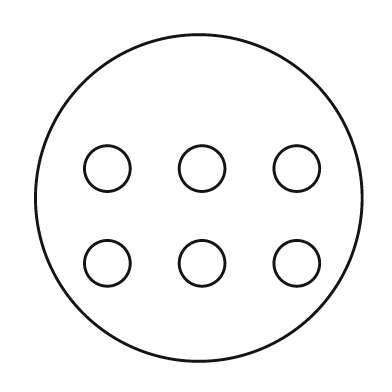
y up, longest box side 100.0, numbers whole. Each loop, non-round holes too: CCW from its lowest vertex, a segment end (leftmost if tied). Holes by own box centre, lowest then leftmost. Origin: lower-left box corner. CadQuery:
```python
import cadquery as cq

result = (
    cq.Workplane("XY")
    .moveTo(50.0, 50.0)
    .circle(50.0)
    .moveTo(22.0, 30.0)
    .circle(7.0)
    .moveTo(51.0, 30.0)
    .circle(7.0)
    .moveTo(80.0, 30.0)
    .circle(7.0)
    .moveTo(22.0, 59.0)
    .circle(7.0)
    .moveTo(51.0, 59.0)
    .circle(7.0)
    .moveTo(80.0, 59.0)
    .circle(7.0)
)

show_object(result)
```